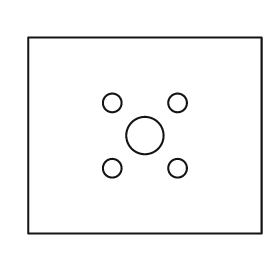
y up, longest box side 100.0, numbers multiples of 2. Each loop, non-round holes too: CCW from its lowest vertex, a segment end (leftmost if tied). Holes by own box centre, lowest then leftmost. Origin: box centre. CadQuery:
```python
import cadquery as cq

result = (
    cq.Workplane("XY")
    .moveTo(-50.0, -42.0)
    .lineTo(50.0, -42.0)
    .lineTo(50.0, 42.0)
    .lineTo(-50.0, 42.0)
    .close()
    .moveTo(-14.0, -14.0)
    .circle(4.0)
    .moveTo(14.0, -14.0)
    .circle(4.0)
    .moveTo(0.0, 0.0)
    .circle(8.0)
    .moveTo(-14.0, 14.0)
    .circle(4.0)
    .moveTo(14.0, 14.0)
    .circle(4.0)
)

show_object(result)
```